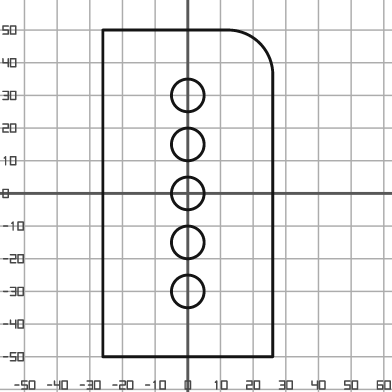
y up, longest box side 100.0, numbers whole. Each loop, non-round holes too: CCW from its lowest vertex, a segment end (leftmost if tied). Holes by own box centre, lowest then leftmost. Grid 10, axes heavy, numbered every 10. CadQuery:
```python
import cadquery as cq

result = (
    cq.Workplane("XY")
    .moveTo(-26.0, -50.0)
    .lineTo(26.0, -50.0)
    .lineTo(26.0, 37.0)
    .threePointArc((22.0, 46.0), (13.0, 50.0))
    .lineTo(-26.0, 50.0)
    .close()
    .moveTo(0.0, -30.0)
    .circle(5.0)
    .moveTo(0.0, -15.0)
    .circle(5.0)
    .moveTo(0.0, 0.0)
    .circle(5.0)
    .moveTo(0.0, 15.0)
    .circle(5.0)
    .moveTo(0.0, 30.0)
    .circle(5.0)
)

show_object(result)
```